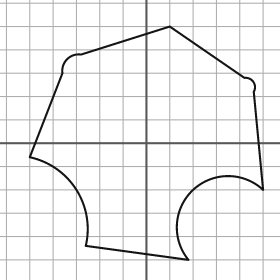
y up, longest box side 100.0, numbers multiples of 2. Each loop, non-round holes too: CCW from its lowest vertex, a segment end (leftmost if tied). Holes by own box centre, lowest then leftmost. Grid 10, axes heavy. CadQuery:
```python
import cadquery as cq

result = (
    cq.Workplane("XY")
    .moveTo(18.0, -50.0)
    .threePointArc((20.0, -20.0), (50.0, -20.0))
    .lineTo(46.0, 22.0)
    .threePointArc((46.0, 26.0), (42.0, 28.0))
    .lineTo(10.0, 50.0)
    .lineTo(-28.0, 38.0)
    .threePointArc((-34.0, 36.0), (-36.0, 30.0))
    .lineTo(-50.0, -6.0)
    .threePointArc((-30.0, -20.0), (-26.0, -44.0))
    .close()
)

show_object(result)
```